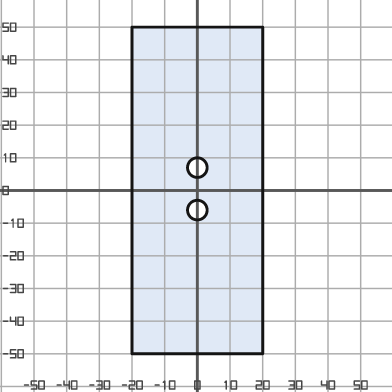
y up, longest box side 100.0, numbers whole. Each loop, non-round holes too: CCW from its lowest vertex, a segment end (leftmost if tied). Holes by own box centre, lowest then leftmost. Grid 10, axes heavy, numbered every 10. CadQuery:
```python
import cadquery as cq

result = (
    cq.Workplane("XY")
    .moveTo(-20.0, -50.0)
    .lineTo(20.0, -50.0)
    .lineTo(20.0, 50.0)
    .lineTo(-20.0, 50.0)
    .close()
    .moveTo(0.0, -6.0)
    .circle(3.0)
    .moveTo(0.0, 7.0)
    .circle(3.0)
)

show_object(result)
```